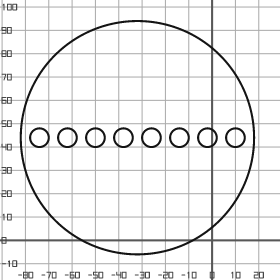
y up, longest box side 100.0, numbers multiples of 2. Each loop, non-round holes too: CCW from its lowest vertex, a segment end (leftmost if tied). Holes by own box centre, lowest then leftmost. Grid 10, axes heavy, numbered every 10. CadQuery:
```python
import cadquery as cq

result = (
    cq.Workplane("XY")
    .moveTo(-32.0, 44.0)
    .circle(50.0)
    .moveTo(-74.0, 44.0)
    .circle(4.0)
    .moveTo(-62.0, 44.0)
    .circle(4.0)
    .moveTo(-50.0, 44.0)
    .circle(4.0)
    .moveTo(-38.0, 44.0)
    .circle(4.0)
    .moveTo(-26.0, 44.0)
    .circle(4.0)
    .moveTo(-14.0, 44.0)
    .circle(4.0)
    .moveTo(-2.0, 44.0)
    .circle(4.0)
    .moveTo(10.0, 44.0)
    .circle(4.0)
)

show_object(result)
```